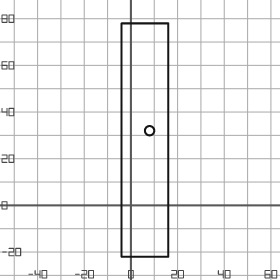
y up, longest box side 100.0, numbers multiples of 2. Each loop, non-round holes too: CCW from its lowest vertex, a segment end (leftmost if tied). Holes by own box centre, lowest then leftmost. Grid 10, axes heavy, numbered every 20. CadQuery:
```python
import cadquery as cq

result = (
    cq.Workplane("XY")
    .moveTo(-4.0, -22.0)
    .lineTo(16.0, -22.0)
    .lineTo(16.0, 78.0)
    .lineTo(-4.0, 78.0)
    .close()
    .moveTo(8.0, 32.0)
    .circle(2.0)
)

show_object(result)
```